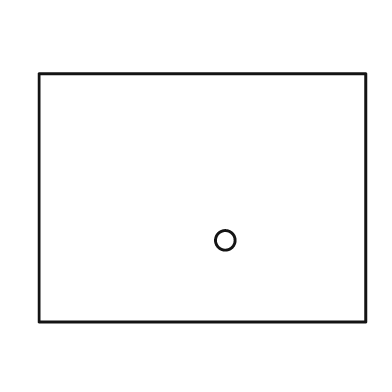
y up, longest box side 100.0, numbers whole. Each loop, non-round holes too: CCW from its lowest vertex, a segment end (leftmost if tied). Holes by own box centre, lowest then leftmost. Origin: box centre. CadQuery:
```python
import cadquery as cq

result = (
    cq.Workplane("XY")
    .moveTo(-50.0, -38.0)
    .lineTo(50.0, -38.0)
    .lineTo(50.0, 38.0)
    .lineTo(-50.0, 38.0)
    .close()
    .moveTo(7.0, -13.0)
    .circle(3.0)
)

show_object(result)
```